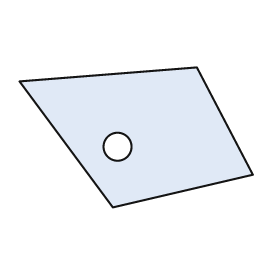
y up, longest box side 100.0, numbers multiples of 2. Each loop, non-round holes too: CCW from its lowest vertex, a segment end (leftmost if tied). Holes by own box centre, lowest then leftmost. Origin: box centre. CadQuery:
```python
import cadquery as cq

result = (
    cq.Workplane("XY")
    .moveTo(-10.0, -30.0)
    .lineTo(50.0, -16.0)
    .lineTo(26.0, 30.0)
    .lineTo(-50.0, 24.0)
    .close()
    .moveTo(-8.0, -4.0)
    .circle(6.0)
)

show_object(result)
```